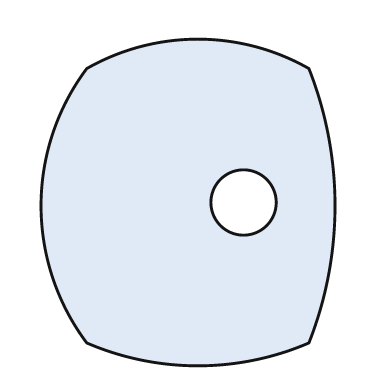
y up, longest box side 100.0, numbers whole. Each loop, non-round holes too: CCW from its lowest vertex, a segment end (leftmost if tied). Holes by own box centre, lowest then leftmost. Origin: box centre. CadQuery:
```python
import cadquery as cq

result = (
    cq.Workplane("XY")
    .moveTo(-31.0, -43.0)
    .threePointArc((3.0, -50.0), (37.0, -43.0))
    .threePointArc((45.0, -1.0), (37.0, 41.0))
    .threePointArc((3.0, 50.0), (-31.0, 41.0))
    .threePointArc((-45.0, -1.0), (-31.0, -43.0))
    .close()
    .moveTo(17.0, 0.0)
    .circle(10.0)
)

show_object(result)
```